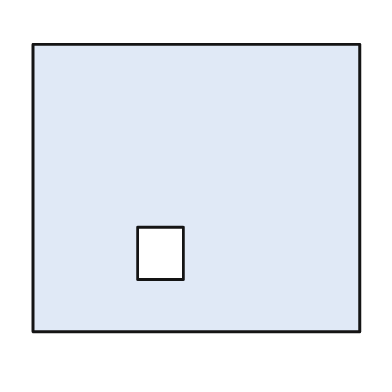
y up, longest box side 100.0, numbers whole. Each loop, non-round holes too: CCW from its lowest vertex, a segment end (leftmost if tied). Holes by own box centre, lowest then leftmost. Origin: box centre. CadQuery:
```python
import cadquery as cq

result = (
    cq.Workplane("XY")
    .moveTo(-50.0, -44.0)
    .lineTo(50.0, -44.0)
    .lineTo(50.0, 44.0)
    .lineTo(-50.0, 44.0)
    .close()
    .moveTo(-18.0, -28.0)
    .lineTo(-4.0, -28.0)
    .lineTo(-4.0, -12.0)
    .lineTo(-18.0, -12.0)
    .close()
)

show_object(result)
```